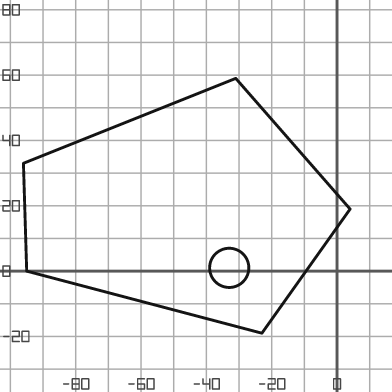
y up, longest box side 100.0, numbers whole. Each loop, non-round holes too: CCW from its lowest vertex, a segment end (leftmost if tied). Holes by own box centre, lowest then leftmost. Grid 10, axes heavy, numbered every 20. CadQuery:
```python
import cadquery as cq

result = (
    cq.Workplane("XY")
    .moveTo(-23.0, -19.0)
    .lineTo(4.0, 19.0)
    .lineTo(-31.0, 59.0)
    .lineTo(-96.0, 33.0)
    .lineTo(-95.0, 0.0)
    .close()
    .moveTo(-33.0, 1.0)
    .circle(6.0)
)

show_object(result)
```